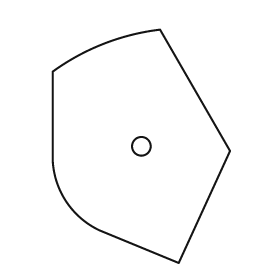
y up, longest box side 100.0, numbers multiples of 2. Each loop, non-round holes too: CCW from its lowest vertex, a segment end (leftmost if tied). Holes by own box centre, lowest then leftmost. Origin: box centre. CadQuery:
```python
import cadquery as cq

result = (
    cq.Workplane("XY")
    .moveTo(16.0, -50.0)
    .lineTo(38.0, -2.0)
    .lineTo(8.0, 50.0)
    .threePointArc((-16.0, 44.0), (-38.0, 32.0))
    .lineTo(-38.0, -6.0)
    .threePointArc((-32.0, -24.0), (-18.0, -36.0))
    .close()
    .moveTo(0.0, 0.0)
    .circle(4.0)
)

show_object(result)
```